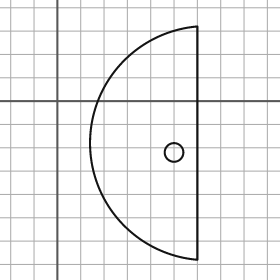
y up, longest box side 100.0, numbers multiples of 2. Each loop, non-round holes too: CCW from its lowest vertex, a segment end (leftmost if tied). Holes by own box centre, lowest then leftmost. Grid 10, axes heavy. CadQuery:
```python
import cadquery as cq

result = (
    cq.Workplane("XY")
    .moveTo(60.0, -68.0)
    .lineTo(60.0, 32.0)
    .threePointArc((14.0, -18.0), (60.0, -68.0))
    .close()
    .moveTo(50.0, -22.0)
    .circle(4.0)
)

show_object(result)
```